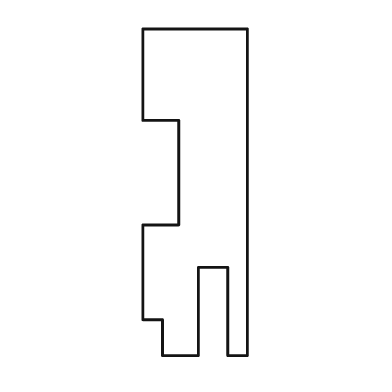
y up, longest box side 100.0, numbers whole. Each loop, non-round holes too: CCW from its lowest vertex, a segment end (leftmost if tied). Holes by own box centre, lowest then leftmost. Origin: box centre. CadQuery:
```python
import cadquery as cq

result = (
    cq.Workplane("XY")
    .moveTo(-10.0, -50.0)
    .lineTo(1.0, -50.0)
    .lineTo(1.0, -23.0)
    .lineTo(10.0, -23.0)
    .lineTo(10.0, -50.0)
    .lineTo(16.0, -50.0)
    .lineTo(16.0, 50.0)
    .lineTo(-16.0, 50.0)
    .lineTo(-16.0, 22.0)
    .lineTo(-5.0, 22.0)
    .lineTo(-5.0, -10.0)
    .lineTo(-16.0, -10.0)
    .lineTo(-16.0, -39.0)
    .lineTo(-10.0, -39.0)
    .close()
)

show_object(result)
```